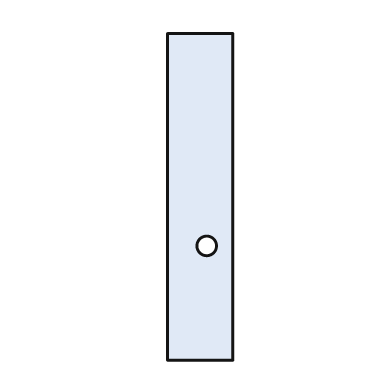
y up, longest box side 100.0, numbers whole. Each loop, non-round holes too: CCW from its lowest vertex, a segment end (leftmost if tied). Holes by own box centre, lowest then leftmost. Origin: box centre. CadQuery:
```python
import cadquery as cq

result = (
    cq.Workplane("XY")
    .moveTo(-10.0, -50.0)
    .lineTo(10.0, -50.0)
    .lineTo(10.0, 50.0)
    .lineTo(-10.0, 50.0)
    .close()
    .moveTo(2.0, -15.0)
    .circle(3.0)
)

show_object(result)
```